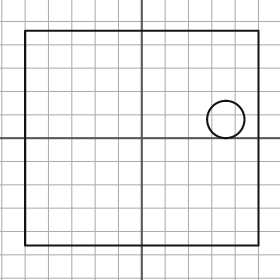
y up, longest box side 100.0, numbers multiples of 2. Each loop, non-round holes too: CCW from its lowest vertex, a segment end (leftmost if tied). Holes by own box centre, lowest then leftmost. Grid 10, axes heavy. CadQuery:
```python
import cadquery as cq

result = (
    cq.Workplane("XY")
    .moveTo(-50.0, -46.0)
    .lineTo(50.0, -46.0)
    .lineTo(50.0, 46.0)
    .lineTo(-50.0, 46.0)
    .close()
    .moveTo(36.0, 8.0)
    .circle(8.0)
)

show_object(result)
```